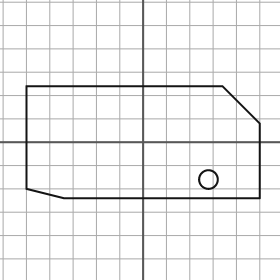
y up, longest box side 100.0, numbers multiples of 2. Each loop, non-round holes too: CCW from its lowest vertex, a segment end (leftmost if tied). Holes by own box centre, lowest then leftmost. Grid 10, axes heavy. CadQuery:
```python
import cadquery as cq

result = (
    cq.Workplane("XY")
    .moveTo(-34.0, -24.0)
    .lineTo(50.0, -24.0)
    .lineTo(50.0, 8.0)
    .lineTo(34.0, 24.0)
    .lineTo(-50.0, 24.0)
    .lineTo(-50.0, -20.0)
    .close()
    .moveTo(28.0, -16.0)
    .circle(4.0)
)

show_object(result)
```